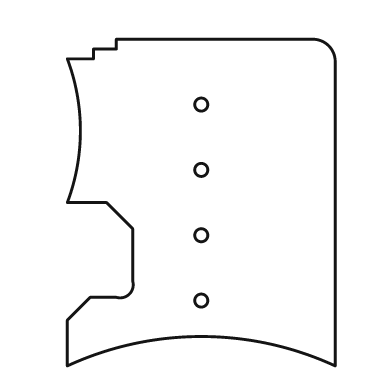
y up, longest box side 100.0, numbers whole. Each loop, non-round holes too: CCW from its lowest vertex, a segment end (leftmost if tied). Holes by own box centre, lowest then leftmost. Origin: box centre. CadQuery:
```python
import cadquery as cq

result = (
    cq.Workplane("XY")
    .moveTo(-41.0, -50.0)
    .threePointArc((0.0, -41.0), (41.0, -50.0))
    .lineTo(41.0, 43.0)
    .threePointArc((39.0, 48.0), (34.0, 50.0))
    .lineTo(-26.0, 50.0)
    .lineTo(-26.0, 47.0)
    .lineTo(-33.0, 47.0)
    .lineTo(-33.0, 44.0)
    .lineTo(-41.0, 44.0)
    .threePointArc((-37.0, 22.0), (-41.0, 0.0))
    .lineTo(-29.0, 0.0)
    .lineTo(-21.0, -8.0)
    .lineTo(-21.0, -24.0)
    .threePointArc((-22.0, -28.0), (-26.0, -29.0))
    .lineTo(-34.0, -29.0)
    .lineTo(-41.0, -36.0)
    .close()
    .moveTo(0.0, -30.0)
    .circle(2.0)
    .moveTo(0.0, -10.0)
    .circle(2.0)
    .moveTo(0.0, 10.0)
    .circle(2.0)
    .moveTo(0.0, 30.0)
    .circle(2.0)
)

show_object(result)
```